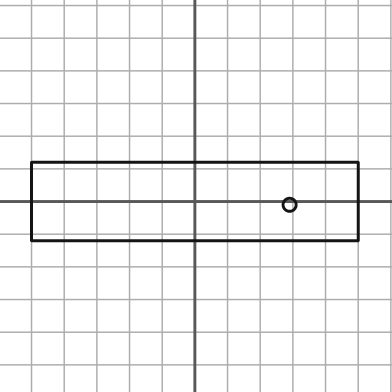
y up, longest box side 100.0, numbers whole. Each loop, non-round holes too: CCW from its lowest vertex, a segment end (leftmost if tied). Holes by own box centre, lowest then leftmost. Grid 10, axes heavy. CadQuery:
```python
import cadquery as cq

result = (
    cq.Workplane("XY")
    .moveTo(-50.0, -12.0)
    .lineTo(50.0, -12.0)
    .lineTo(50.0, 12.0)
    .lineTo(-50.0, 12.0)
    .close()
    .moveTo(29.0, -1.0)
    .circle(2.0)
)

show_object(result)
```